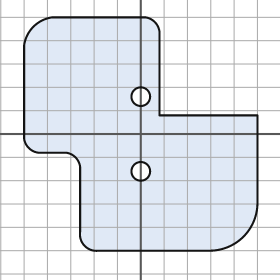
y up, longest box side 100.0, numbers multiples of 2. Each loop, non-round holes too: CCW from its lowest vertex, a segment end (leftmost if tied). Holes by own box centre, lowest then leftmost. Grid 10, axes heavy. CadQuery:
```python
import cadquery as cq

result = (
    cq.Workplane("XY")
    .moveTo(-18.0, -50.0)
    .lineTo(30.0, -50.0)
    .threePointArc((44.0, -44.0), (50.0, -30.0))
    .lineTo(50.0, 8.0)
    .lineTo(8.0, 8.0)
    .lineTo(8.0, 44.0)
    .threePointArc((6.0, 48.0), (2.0, 50.0))
    .lineTo(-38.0, 50.0)
    .threePointArc((-46.0, 46.0), (-50.0, 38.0))
    .lineTo(-50.0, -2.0)
    .threePointArc((-48.0, -6.0), (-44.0, -8.0))
    .lineTo(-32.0, -8.0)
    .threePointArc((-28.0, -10.0), (-26.0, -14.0))
    .lineTo(-26.0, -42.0)
    .threePointArc((-24.0, -48.0), (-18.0, -50.0))
    .close()
    .moveTo(0.0, -16.0)
    .circle(4.0)
    .moveTo(0.0, 16.0)
    .circle(4.0)
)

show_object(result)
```